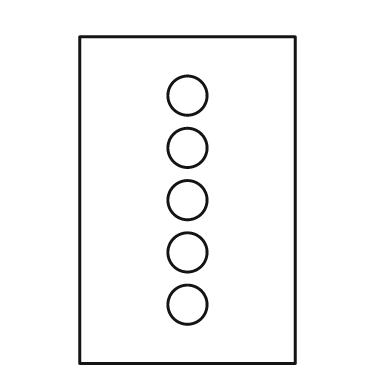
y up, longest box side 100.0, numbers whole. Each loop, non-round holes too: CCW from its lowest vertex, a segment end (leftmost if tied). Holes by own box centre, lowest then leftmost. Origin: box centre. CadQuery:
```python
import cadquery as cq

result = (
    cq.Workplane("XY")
    .moveTo(-33.0, -50.0)
    .lineTo(33.0, -50.0)
    .lineTo(33.0, 50.0)
    .lineTo(-33.0, 50.0)
    .close()
    .moveTo(0.0, -32.0)
    .circle(6.0)
    .moveTo(0.0, -16.0)
    .circle(6.0)
    .moveTo(0.0, 0.0)
    .circle(6.0)
    .moveTo(0.0, 16.0)
    .circle(6.0)
    .moveTo(0.0, 32.0)
    .circle(6.0)
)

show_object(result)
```